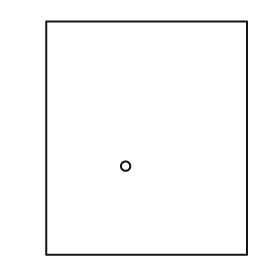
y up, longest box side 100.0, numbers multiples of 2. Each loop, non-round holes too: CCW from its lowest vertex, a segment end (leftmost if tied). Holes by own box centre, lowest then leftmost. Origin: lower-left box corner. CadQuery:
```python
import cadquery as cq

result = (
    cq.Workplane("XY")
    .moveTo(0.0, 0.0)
    .lineTo(86.0, 0.0)
    .lineTo(86.0, 100.0)
    .lineTo(0.0, 100.0)
    .close()
    .moveTo(34.0, 38.0)
    .circle(2.0)
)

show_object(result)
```